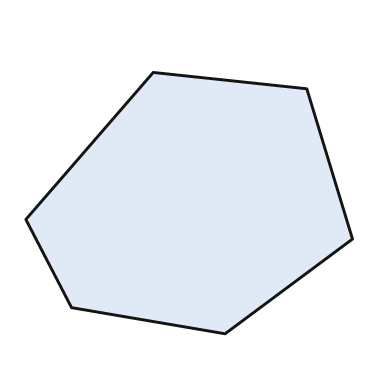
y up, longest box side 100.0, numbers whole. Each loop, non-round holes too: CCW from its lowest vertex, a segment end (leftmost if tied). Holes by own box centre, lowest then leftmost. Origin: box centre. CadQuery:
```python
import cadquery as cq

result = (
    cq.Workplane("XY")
    .moveTo(11.0, -40.0)
    .lineTo(50.0, -11.0)
    .lineTo(36.0, 35.0)
    .lineTo(-11.0, 40.0)
    .lineTo(-50.0, -5.0)
    .lineTo(-36.0, -32.0)
    .close()
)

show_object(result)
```